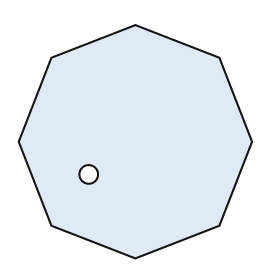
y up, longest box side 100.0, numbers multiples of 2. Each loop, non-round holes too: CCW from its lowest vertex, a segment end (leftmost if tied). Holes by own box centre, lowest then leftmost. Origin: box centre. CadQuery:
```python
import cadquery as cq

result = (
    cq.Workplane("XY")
    .moveTo(0.0, -50.0)
    .lineTo(36.0, -36.0)
    .lineTo(50.0, 0.0)
    .lineTo(36.0, 36.0)
    .lineTo(0.0, 50.0)
    .lineTo(-36.0, 36.0)
    .lineTo(-50.0, 0.0)
    .lineTo(-36.0, -36.0)
    .close()
    .moveTo(-20.0, -14.0)
    .circle(4.0)
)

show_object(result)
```